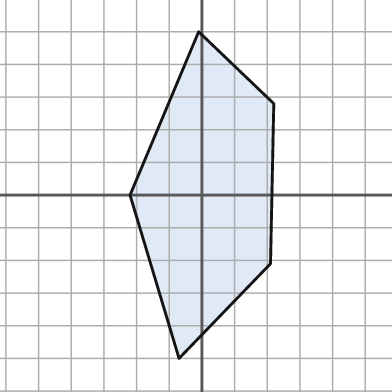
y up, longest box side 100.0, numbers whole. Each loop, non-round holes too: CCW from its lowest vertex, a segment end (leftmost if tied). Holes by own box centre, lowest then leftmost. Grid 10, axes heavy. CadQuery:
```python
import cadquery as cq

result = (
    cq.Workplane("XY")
    .moveTo(-7.0, -50.0)
    .lineTo(21.0, -21.0)
    .lineTo(22.0, 28.0)
    .lineTo(-1.0, 50.0)
    .lineTo(-22.0, 0.0)
    .close()
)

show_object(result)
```